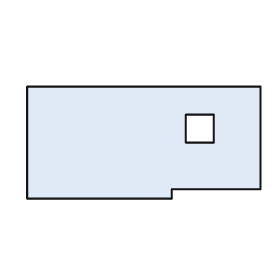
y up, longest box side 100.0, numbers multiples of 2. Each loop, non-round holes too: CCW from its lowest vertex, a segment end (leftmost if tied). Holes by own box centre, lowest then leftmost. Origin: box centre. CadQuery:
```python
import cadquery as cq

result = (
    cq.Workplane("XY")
    .moveTo(-50.0, -24.0)
    .lineTo(12.0, -24.0)
    .lineTo(12.0, -20.0)
    .lineTo(50.0, -20.0)
    .lineTo(50.0, 24.0)
    .lineTo(-50.0, 24.0)
    .close()
    .moveTo(18.0, 0.0)
    .lineTo(30.0, 0.0)
    .lineTo(30.0, 12.0)
    .lineTo(18.0, 12.0)
    .close()
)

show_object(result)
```